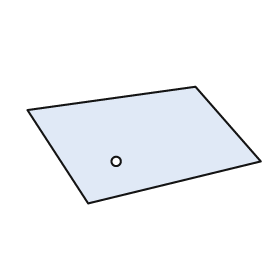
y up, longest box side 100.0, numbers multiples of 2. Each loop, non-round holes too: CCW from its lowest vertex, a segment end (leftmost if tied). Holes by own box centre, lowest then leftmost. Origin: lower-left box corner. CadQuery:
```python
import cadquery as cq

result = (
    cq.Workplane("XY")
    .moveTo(26.0, 0.0)
    .lineTo(100.0, 18.0)
    .lineTo(72.0, 50.0)
    .lineTo(0.0, 40.0)
    .close()
    .moveTo(38.0, 18.0)
    .circle(2.0)
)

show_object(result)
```